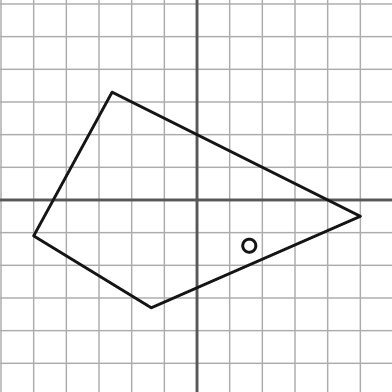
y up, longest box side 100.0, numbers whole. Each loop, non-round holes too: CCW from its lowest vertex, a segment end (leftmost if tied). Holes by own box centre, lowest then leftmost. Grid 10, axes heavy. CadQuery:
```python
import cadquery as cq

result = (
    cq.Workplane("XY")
    .moveTo(-14.0, -33.0)
    .lineTo(50.0, -5.0)
    .lineTo(-26.0, 33.0)
    .lineTo(-50.0, -11.0)
    .close()
    .moveTo(16.0, -14.0)
    .circle(2.0)
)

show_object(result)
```